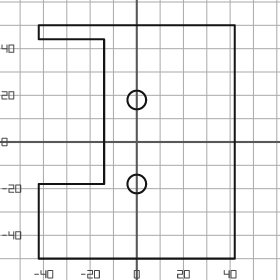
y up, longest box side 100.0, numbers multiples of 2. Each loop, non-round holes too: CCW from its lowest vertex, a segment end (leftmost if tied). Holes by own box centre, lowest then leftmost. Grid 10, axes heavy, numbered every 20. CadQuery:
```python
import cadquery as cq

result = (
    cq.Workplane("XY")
    .moveTo(-42.0, -50.0)
    .lineTo(42.0, -50.0)
    .lineTo(42.0, 50.0)
    .lineTo(-42.0, 50.0)
    .lineTo(-42.0, 44.0)
    .lineTo(-14.0, 44.0)
    .lineTo(-14.0, -18.0)
    .lineTo(-42.0, -18.0)
    .close()
    .moveTo(0.0, -18.0)
    .circle(4.0)
    .moveTo(0.0, 18.0)
    .circle(4.0)
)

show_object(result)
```